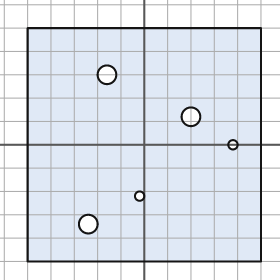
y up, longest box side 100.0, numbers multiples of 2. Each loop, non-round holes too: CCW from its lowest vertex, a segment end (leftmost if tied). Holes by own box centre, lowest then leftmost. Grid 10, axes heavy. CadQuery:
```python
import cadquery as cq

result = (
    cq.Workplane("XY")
    .moveTo(-50.0, -50.0)
    .lineTo(50.0, -50.0)
    .lineTo(50.0, 50.0)
    .lineTo(-50.0, 50.0)
    .close()
    .moveTo(-24.0, -34.0)
    .circle(4.0)
    .moveTo(-2.0, -22.0)
    .circle(2.0)
    .moveTo(38.0, 0.0)
    .circle(2.0)
    .moveTo(20.0, 12.0)
    .circle(4.0)
    .moveTo(-16.0, 30.0)
    .circle(4.0)
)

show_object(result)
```